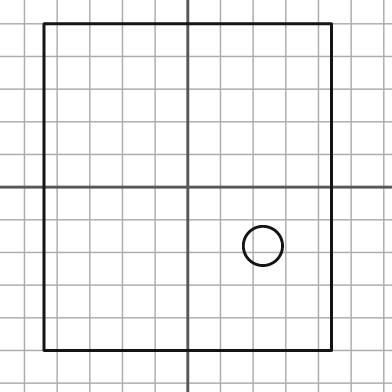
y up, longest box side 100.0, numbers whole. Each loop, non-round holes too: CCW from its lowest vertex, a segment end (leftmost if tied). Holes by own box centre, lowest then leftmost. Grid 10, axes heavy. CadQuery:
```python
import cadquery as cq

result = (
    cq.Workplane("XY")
    .moveTo(-44.0, -50.0)
    .lineTo(44.0, -50.0)
    .lineTo(44.0, 50.0)
    .lineTo(-44.0, 50.0)
    .close()
    .moveTo(23.0, -18.0)
    .circle(6.0)
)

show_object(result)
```